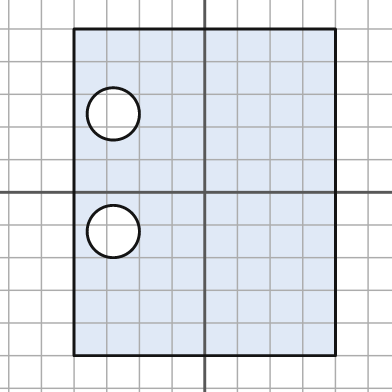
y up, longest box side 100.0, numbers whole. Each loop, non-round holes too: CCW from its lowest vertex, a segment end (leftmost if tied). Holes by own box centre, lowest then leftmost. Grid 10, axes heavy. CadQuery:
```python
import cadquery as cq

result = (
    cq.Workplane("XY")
    .moveTo(-40.0, -50.0)
    .lineTo(40.0, -50.0)
    .lineTo(40.0, 50.0)
    .lineTo(-40.0, 50.0)
    .close()
    .moveTo(-28.0, -12.0)
    .circle(8.0)
    .moveTo(-28.0, 24.0)
    .circle(8.0)
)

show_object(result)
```